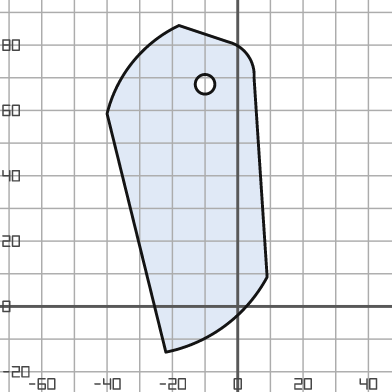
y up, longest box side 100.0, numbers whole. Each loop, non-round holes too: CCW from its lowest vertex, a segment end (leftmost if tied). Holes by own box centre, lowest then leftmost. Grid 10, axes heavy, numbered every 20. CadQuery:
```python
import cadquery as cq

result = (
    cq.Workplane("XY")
    .moveTo(-22.0, -14.0)
    .threePointArc((-4.0, -6.0), (9.0, 9.0))
    .lineTo(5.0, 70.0)
    .threePointArc((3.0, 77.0), (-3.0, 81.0))
    .lineTo(-18.0, 86.0)
    .threePointArc((-32.0, 75.0), (-40.0, 59.0))
    .close()
    .moveTo(-10.0, 68.0)
    .circle(3.0)
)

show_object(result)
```